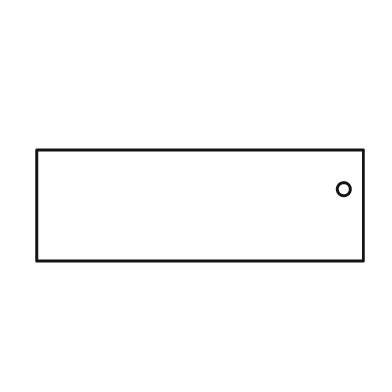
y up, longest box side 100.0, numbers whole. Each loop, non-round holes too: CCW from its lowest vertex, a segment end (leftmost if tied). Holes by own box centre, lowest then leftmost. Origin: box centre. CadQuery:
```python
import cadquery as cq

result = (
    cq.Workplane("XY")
    .moveTo(-50.0, -17.0)
    .lineTo(50.0, -17.0)
    .lineTo(50.0, 17.0)
    .lineTo(-50.0, 17.0)
    .close()
    .moveTo(44.0, 5.0)
    .circle(2.0)
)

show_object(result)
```